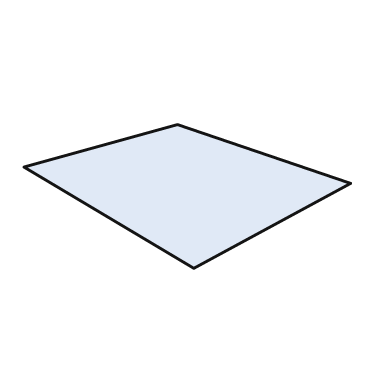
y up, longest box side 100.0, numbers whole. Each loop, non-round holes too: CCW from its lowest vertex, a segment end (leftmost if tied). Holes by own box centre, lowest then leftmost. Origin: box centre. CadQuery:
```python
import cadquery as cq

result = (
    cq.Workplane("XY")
    .moveTo(2.0, -22.0)
    .lineTo(50.0, 4.0)
    .lineTo(-3.0, 22.0)
    .lineTo(-50.0, 9.0)
    .close()
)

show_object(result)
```